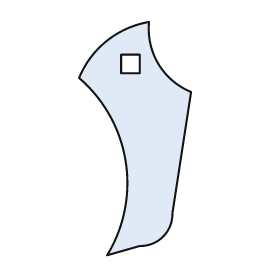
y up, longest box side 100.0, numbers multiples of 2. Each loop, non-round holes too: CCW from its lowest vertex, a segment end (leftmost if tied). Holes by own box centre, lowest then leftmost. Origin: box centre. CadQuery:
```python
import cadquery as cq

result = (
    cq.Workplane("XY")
    .moveTo(-12.0, -50.0)
    .lineTo(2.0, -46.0)
    .threePointArc((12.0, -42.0), (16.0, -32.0))
    .lineTo(24.0, 20.0)
    .threePointArc((10.0, 32.0), (6.0, 50.0))
    .threePointArc((-12.0, 42.0), (-24.0, 26.0))
    .threePointArc((-4.0, -10.0), (-12.0, -50.0))
    .close()
    .moveTo(-6.0, 28.0)
    .lineTo(2.0, 28.0)
    .lineTo(2.0, 36.0)
    .lineTo(-6.0, 36.0)
    .close()
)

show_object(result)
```